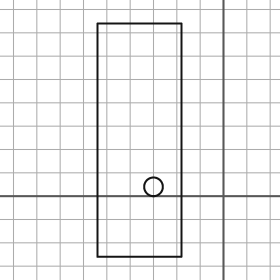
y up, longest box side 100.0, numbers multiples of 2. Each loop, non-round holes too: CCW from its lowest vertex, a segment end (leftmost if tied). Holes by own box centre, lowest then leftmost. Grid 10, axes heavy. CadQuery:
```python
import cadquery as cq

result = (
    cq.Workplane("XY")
    .moveTo(-54.0, -26.0)
    .lineTo(-18.0, -26.0)
    .lineTo(-18.0, 74.0)
    .lineTo(-54.0, 74.0)
    .close()
    .moveTo(-30.0, 4.0)
    .circle(4.0)
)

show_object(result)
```